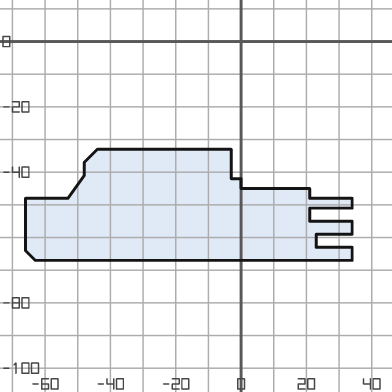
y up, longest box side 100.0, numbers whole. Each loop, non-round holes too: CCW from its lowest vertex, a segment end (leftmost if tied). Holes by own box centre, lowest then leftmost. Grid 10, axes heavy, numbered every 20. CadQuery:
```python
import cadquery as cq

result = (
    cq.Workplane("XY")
    .moveTo(-63.0, -67.0)
    .lineTo(34.0, -67.0)
    .lineTo(34.0, -63.0)
    .lineTo(23.0, -63.0)
    .lineTo(23.0, -59.0)
    .lineTo(34.0, -59.0)
    .lineTo(34.0, -55.0)
    .lineTo(21.0, -55.0)
    .lineTo(21.0, -51.0)
    .lineTo(34.0, -51.0)
    .lineTo(34.0, -48.0)
    .lineTo(21.0, -48.0)
    .lineTo(21.0, -45.0)
    .lineTo(0.0, -45.0)
    .lineTo(0.0, -42.0)
    .lineTo(-3.0, -42.0)
    .lineTo(-3.0, -33.0)
    .lineTo(-44.0, -33.0)
    .lineTo(-48.0, -37.0)
    .lineTo(-48.0, -41.0)
    .lineTo(-53.0, -48.0)
    .lineTo(-66.0, -48.0)
    .lineTo(-66.0, -64.0)
    .close()
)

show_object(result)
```